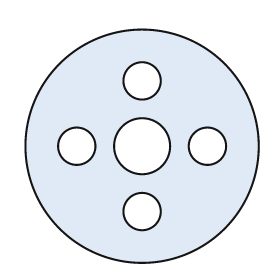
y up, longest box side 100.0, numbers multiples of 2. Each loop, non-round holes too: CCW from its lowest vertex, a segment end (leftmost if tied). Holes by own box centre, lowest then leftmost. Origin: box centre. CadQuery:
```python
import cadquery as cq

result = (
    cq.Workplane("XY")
    .moveTo(0.0, 0.0)
    .circle(50.0)
    .moveTo(0.0, -28.0)
    .circle(8.0)
    .moveTo(-28.0, 0.0)
    .circle(8.0)
    .moveTo(0.0, 0.0)
    .circle(12.0)
    .moveTo(28.0, 0.0)
    .circle(8.0)
    .moveTo(0.0, 28.0)
    .circle(8.0)
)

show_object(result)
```